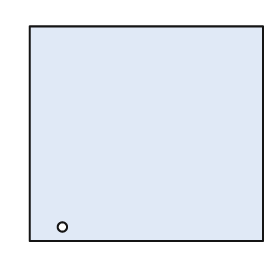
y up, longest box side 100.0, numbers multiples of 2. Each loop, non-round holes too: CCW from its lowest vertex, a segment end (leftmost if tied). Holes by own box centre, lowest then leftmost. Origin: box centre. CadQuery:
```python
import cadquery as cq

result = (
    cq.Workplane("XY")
    .moveTo(-50.0, -46.0)
    .lineTo(50.0, -46.0)
    .lineTo(50.0, 46.0)
    .lineTo(-50.0, 46.0)
    .close()
    .moveTo(-36.0, -40.0)
    .circle(2.0)
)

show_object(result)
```